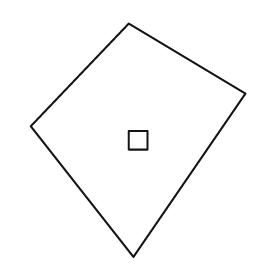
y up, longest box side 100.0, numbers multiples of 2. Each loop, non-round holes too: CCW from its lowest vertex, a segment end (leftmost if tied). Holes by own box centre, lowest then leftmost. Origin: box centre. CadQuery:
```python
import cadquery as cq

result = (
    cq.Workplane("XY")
    .moveTo(-2.0, -50.0)
    .lineTo(46.0, 20.0)
    .lineTo(-4.0, 50.0)
    .lineTo(-46.0, 6.0)
    .close()
    .moveTo(-4.0, -4.0)
    .lineTo(4.0, -4.0)
    .lineTo(4.0, 4.0)
    .lineTo(-4.0, 4.0)
    .close()
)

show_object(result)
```